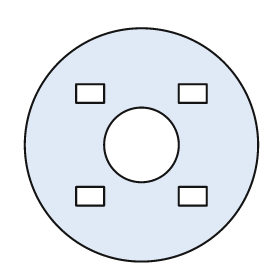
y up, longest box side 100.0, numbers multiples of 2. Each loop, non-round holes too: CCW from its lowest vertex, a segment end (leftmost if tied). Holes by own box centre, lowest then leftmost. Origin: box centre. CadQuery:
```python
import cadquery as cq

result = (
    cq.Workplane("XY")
    .moveTo(0.0, 0.0)
    .circle(50.0)
    .moveTo(-28.0, -26.0)
    .lineTo(-16.0, -26.0)
    .lineTo(-16.0, -18.0)
    .lineTo(-28.0, -18.0)
    .close()
    .moveTo(16.0, -26.0)
    .lineTo(28.0, -26.0)
    .lineTo(28.0, -18.0)
    .lineTo(16.0, -18.0)
    .close()
    .moveTo(0.0, 0.0)
    .circle(16.0)
    .moveTo(-28.0, 18.0)
    .lineTo(-16.0, 18.0)
    .lineTo(-16.0, 26.0)
    .lineTo(-28.0, 26.0)
    .close()
    .moveTo(16.0, 18.0)
    .lineTo(28.0, 18.0)
    .lineTo(28.0, 26.0)
    .lineTo(16.0, 26.0)
    .close()
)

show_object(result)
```